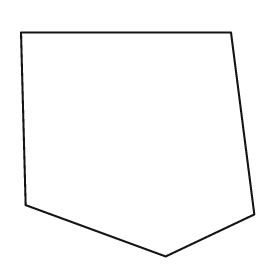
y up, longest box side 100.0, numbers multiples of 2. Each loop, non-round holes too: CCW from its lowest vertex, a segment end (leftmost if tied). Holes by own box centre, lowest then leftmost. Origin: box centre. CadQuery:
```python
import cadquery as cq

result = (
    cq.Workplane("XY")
    .moveTo(12.0, -48.0)
    .lineTo(50.0, -30.0)
    .lineTo(40.0, 48.0)
    .lineTo(-50.0, 48.0)
    .lineTo(-48.0, -26.0)
    .close()
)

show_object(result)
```